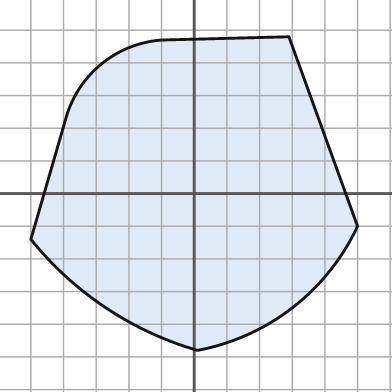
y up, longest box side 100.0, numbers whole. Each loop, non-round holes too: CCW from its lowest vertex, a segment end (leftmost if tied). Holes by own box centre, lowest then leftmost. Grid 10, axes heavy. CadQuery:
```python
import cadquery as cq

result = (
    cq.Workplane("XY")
    .moveTo(1.0, -48.0)
    .threePointArc((30.0, -35.0), (50.0, -10.0))
    .lineTo(29.0, 48.0)
    .lineTo(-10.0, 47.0)
    .threePointArc((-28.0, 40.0), (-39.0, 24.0))
    .lineTo(-50.0, -14.0)
    .threePointArc((-27.0, -35.0), (1.0, -48.0))
    .close()
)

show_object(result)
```